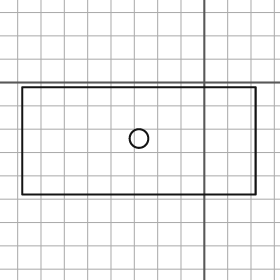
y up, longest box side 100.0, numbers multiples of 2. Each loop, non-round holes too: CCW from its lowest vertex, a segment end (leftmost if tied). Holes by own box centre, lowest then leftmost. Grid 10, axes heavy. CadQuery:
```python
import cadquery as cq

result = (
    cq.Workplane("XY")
    .moveTo(-78.0, -48.0)
    .lineTo(22.0, -48.0)
    .lineTo(22.0, -2.0)
    .lineTo(-78.0, -2.0)
    .close()
    .moveTo(-28.0, -24.0)
    .circle(4.0)
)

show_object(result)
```